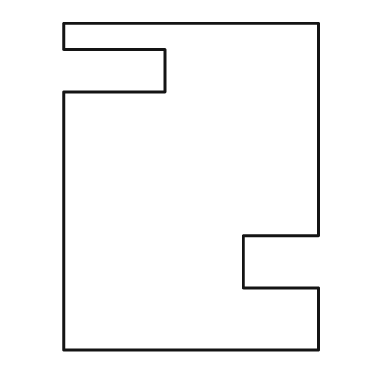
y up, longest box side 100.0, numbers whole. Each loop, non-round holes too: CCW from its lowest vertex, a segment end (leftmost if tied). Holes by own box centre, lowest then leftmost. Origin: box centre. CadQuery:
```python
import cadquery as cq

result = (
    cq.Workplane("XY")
    .moveTo(-39.0, -50.0)
    .lineTo(39.0, -50.0)
    .lineTo(39.0, -31.0)
    .lineTo(16.0, -31.0)
    .lineTo(16.0, -15.0)
    .lineTo(39.0, -15.0)
    .lineTo(39.0, 50.0)
    .lineTo(-39.0, 50.0)
    .lineTo(-39.0, 42.0)
    .lineTo(-8.0, 42.0)
    .lineTo(-8.0, 29.0)
    .lineTo(-39.0, 29.0)
    .close()
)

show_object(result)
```